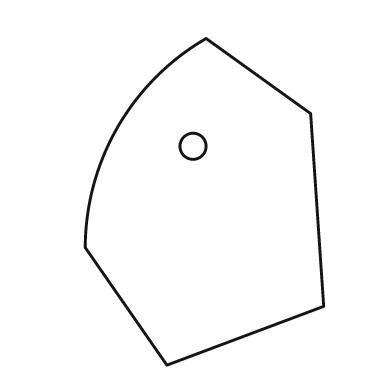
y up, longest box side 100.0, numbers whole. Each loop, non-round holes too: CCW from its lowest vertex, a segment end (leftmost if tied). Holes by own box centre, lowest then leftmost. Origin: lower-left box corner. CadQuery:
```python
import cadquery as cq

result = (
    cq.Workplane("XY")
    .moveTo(25.0, 0.0)
    .lineTo(73.0, 18.0)
    .lineTo(69.0, 77.0)
    .lineTo(37.0, 100.0)
    .threePointArc((10.0, 73.0), (0.0, 36.0))
    .close()
    .moveTo(33.0, 67.0)
    .circle(4.0)
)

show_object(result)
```